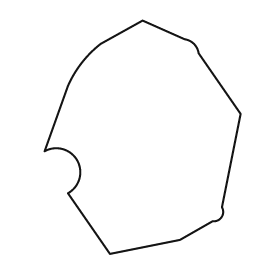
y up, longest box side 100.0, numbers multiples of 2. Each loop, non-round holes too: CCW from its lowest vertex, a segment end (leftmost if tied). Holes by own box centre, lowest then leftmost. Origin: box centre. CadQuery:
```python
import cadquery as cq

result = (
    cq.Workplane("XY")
    .moveTo(-14.0, -50.0)
    .lineTo(16.0, -44.0)
    .lineTo(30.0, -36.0)
    .threePointArc((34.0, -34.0), (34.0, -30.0))
    .lineTo(42.0, 10.0)
    .lineTo(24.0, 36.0)
    .threePointArc((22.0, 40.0), (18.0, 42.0))
    .lineTo(0.0, 50.0)
    .lineTo(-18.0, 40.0)
    .threePointArc((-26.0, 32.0), (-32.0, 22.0))
    .lineTo(-42.0, -6.0)
    .threePointArc((-28.0, -10.0), (-32.0, -24.0))
    .close()
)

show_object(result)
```